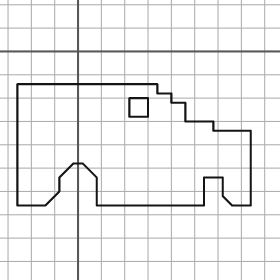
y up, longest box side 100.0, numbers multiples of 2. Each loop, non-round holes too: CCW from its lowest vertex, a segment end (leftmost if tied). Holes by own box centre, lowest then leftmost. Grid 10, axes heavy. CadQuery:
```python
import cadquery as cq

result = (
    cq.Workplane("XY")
    .moveTo(-26.0, -66.0)
    .lineTo(-14.0, -66.0)
    .lineTo(-8.0, -60.0)
    .lineTo(-8.0, -54.0)
    .lineTo(-2.0, -48.0)
    .lineTo(2.0, -48.0)
    .lineTo(8.0, -54.0)
    .lineTo(8.0, -66.0)
    .lineTo(54.0, -66.0)
    .lineTo(54.0, -54.0)
    .lineTo(62.0, -54.0)
    .lineTo(62.0, -62.0)
    .lineTo(66.0, -66.0)
    .lineTo(74.0, -66.0)
    .lineTo(74.0, -34.0)
    .lineTo(58.0, -34.0)
    .lineTo(58.0, -30.0)
    .lineTo(46.0, -30.0)
    .lineTo(46.0, -22.0)
    .lineTo(40.0, -22.0)
    .lineTo(40.0, -18.0)
    .lineTo(34.0, -18.0)
    .lineTo(34.0, -14.0)
    .lineTo(-26.0, -14.0)
    .close()
    .moveTo(22.0, -28.0)
    .lineTo(30.0, -28.0)
    .lineTo(30.0, -20.0)
    .lineTo(22.0, -20.0)
    .close()
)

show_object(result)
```